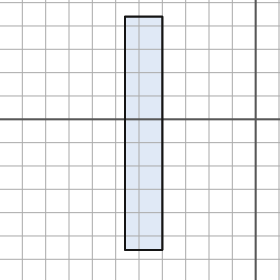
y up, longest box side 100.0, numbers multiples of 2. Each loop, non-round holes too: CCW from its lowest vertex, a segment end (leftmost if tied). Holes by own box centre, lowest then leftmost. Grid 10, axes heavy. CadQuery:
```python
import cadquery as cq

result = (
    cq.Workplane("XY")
    .moveTo(-56.0, -56.0)
    .lineTo(-40.0, -56.0)
    .lineTo(-40.0, 44.0)
    .lineTo(-56.0, 44.0)
    .close()
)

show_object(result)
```